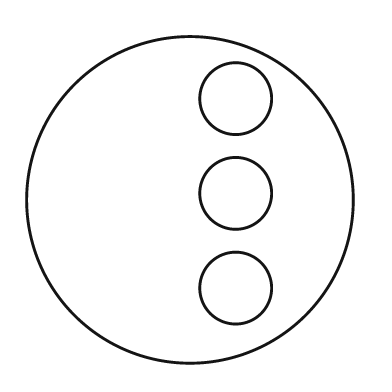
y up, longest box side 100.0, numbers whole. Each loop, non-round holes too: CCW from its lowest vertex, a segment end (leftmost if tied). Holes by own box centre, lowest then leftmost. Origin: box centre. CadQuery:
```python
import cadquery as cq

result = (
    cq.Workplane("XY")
    .moveTo(0.0, 0.0)
    .circle(50.0)
    .moveTo(14.0, -27.0)
    .circle(11.0)
    .moveTo(14.0, 2.0)
    .circle(11.0)
    .moveTo(14.0, 31.0)
    .circle(11.0)
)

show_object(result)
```